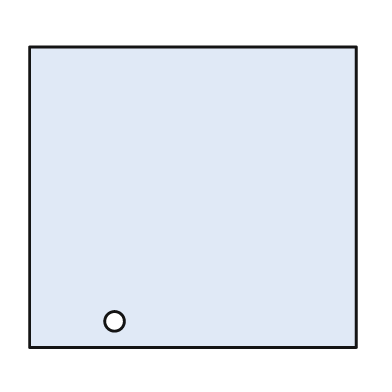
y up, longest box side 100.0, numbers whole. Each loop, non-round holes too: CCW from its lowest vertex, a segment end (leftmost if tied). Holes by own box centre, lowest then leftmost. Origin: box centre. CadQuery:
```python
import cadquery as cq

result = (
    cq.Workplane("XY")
    .moveTo(-50.0, -46.0)
    .lineTo(50.0, -46.0)
    .lineTo(50.0, 46.0)
    .lineTo(-50.0, 46.0)
    .close()
    .moveTo(-24.0, -38.0)
    .circle(3.0)
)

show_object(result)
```